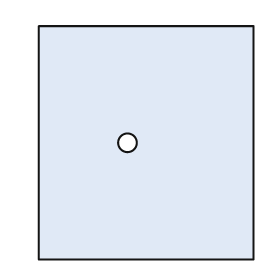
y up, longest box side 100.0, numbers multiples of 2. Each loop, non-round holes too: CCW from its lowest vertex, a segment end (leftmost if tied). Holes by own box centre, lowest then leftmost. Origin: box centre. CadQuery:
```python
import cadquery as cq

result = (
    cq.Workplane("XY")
    .moveTo(-46.0, -50.0)
    .lineTo(46.0, -50.0)
    .lineTo(46.0, 50.0)
    .lineTo(-46.0, 50.0)
    .close()
    .moveTo(-8.0, 0.0)
    .circle(4.0)
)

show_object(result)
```